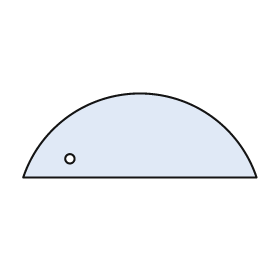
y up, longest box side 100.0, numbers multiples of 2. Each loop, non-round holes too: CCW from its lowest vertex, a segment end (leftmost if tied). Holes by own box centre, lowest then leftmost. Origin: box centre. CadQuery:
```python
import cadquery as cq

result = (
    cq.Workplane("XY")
    .moveTo(-50.0, -18.0)
    .lineTo(50.0, -18.0)
    .threePointArc((0.0, 18.0), (-50.0, -18.0))
    .close()
    .moveTo(-30.0, -10.0)
    .circle(2.0)
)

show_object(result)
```